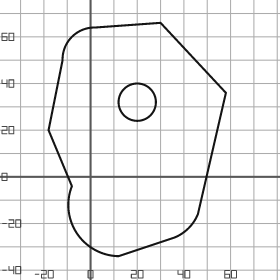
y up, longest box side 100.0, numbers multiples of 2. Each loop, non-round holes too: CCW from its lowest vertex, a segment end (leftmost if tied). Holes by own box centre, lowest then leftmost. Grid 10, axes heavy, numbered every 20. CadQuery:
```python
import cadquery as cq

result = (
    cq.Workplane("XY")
    .moveTo(12.0, -34.0)
    .lineTo(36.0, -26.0)
    .threePointArc((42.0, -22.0), (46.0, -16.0))
    .lineTo(58.0, 36.0)
    .lineTo(30.0, 66.0)
    .lineTo(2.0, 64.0)
    .threePointArc((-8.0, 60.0), (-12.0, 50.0))
    .lineTo(-18.0, 20.0)
    .lineTo(-8.0, -4.0)
    .threePointArc((-6.0, -24.0), (12.0, -34.0))
    .close()
    .moveTo(20.0, 32.0)
    .circle(8.0)
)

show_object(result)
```